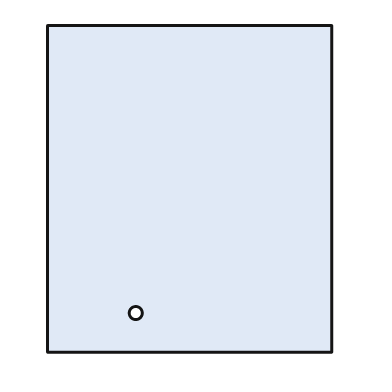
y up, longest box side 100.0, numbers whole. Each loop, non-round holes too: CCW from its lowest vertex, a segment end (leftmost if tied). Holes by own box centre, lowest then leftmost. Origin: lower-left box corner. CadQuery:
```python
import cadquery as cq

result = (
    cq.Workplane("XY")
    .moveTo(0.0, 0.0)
    .lineTo(87.0, 0.0)
    .lineTo(87.0, 100.0)
    .lineTo(0.0, 100.0)
    .close()
    .moveTo(27.0, 12.0)
    .circle(2.0)
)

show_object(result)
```